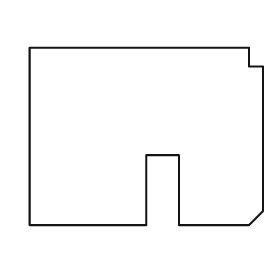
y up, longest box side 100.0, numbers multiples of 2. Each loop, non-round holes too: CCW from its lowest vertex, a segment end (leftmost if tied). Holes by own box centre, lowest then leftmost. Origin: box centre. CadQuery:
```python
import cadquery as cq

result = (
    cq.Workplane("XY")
    .moveTo(-50.0, -38.0)
    .lineTo(0.0, -38.0)
    .lineTo(0.0, -8.0)
    .lineTo(14.0, -8.0)
    .lineTo(14.0, -38.0)
    .lineTo(44.0, -38.0)
    .lineTo(50.0, -32.0)
    .lineTo(50.0, 30.0)
    .lineTo(44.0, 30.0)
    .lineTo(44.0, 38.0)
    .lineTo(-50.0, 38.0)
    .close()
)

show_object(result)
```